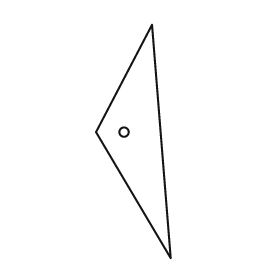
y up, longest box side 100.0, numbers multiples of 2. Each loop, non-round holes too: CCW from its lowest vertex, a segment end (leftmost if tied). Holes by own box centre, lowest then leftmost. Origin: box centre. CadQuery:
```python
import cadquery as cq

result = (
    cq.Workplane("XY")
    .moveTo(16.0, -50.0)
    .lineTo(8.0, 50.0)
    .lineTo(-16.0, 4.0)
    .close()
    .moveTo(-4.0, 4.0)
    .circle(2.0)
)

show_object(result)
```